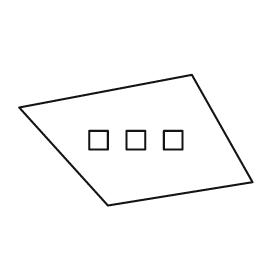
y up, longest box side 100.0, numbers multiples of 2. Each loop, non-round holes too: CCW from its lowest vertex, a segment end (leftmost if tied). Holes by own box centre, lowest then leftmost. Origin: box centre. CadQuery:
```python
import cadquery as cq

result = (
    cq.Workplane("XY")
    .moveTo(-12.0, -28.0)
    .lineTo(50.0, -18.0)
    .lineTo(24.0, 28.0)
    .lineTo(-50.0, 14.0)
    .close()
    .moveTo(-20.0, -4.0)
    .lineTo(-12.0, -4.0)
    .lineTo(-12.0, 4.0)
    .lineTo(-20.0, 4.0)
    .close()
    .moveTo(-4.0, -4.0)
    .lineTo(4.0, -4.0)
    .lineTo(4.0, 4.0)
    .lineTo(-4.0, 4.0)
    .close()
    .moveTo(12.0, -4.0)
    .lineTo(20.0, -4.0)
    .lineTo(20.0, 4.0)
    .lineTo(12.0, 4.0)
    .close()
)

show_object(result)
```